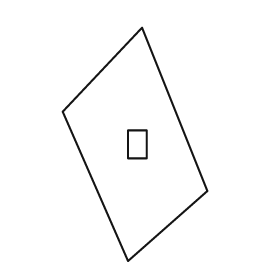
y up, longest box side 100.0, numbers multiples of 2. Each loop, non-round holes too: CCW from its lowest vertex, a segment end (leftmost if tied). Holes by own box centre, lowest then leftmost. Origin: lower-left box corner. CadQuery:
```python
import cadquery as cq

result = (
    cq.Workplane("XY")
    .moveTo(28.0, 0.0)
    .lineTo(62.0, 30.0)
    .lineTo(34.0, 100.0)
    .lineTo(0.0, 64.0)
    .close()
    .moveTo(28.0, 44.0)
    .lineTo(36.0, 44.0)
    .lineTo(36.0, 56.0)
    .lineTo(28.0, 56.0)
    .close()
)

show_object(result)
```